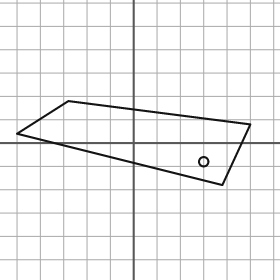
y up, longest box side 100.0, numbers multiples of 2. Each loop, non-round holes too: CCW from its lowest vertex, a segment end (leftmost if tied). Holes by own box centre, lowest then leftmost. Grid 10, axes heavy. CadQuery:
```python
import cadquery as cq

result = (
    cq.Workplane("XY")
    .moveTo(38.0, -18.0)
    .lineTo(50.0, 8.0)
    .lineTo(-28.0, 18.0)
    .lineTo(-50.0, 4.0)
    .close()
    .moveTo(30.0, -8.0)
    .circle(2.0)
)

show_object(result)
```